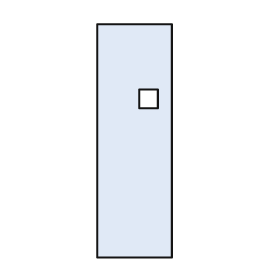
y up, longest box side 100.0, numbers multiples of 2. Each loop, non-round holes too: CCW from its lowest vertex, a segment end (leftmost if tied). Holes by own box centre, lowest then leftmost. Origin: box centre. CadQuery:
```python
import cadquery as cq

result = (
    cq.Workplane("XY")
    .moveTo(-16.0, -50.0)
    .lineTo(16.0, -50.0)
    .lineTo(16.0, 50.0)
    .lineTo(-16.0, 50.0)
    .close()
    .moveTo(2.0, 14.0)
    .lineTo(10.0, 14.0)
    .lineTo(10.0, 22.0)
    .lineTo(2.0, 22.0)
    .close()
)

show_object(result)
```